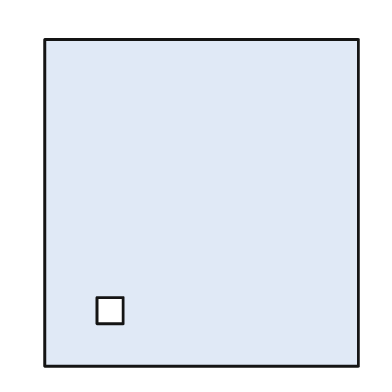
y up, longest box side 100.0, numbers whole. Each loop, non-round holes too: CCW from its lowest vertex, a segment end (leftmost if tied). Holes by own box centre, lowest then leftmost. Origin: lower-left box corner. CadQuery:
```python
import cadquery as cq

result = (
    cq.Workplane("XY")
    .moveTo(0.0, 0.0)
    .lineTo(96.0, 0.0)
    .lineTo(96.0, 100.0)
    .lineTo(0.0, 100.0)
    .close()
    .moveTo(16.0, 13.0)
    .lineTo(24.0, 13.0)
    .lineTo(24.0, 21.0)
    .lineTo(16.0, 21.0)
    .close()
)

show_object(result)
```